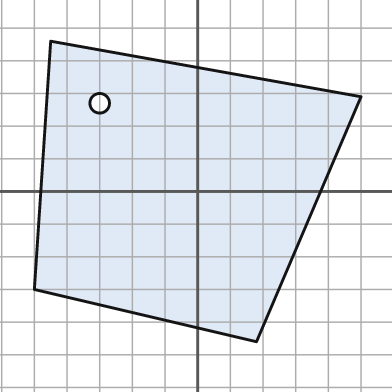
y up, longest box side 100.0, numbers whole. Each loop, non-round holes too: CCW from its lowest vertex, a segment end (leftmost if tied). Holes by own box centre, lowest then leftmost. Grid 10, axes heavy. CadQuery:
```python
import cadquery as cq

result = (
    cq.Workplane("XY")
    .moveTo(18.0, -46.0)
    .lineTo(50.0, 29.0)
    .lineTo(-45.0, 46.0)
    .lineTo(-50.0, -30.0)
    .close()
    .moveTo(-30.0, 27.0)
    .circle(3.0)
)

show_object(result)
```